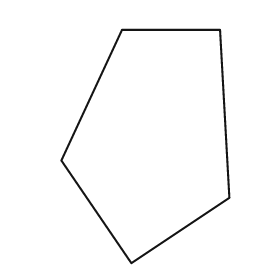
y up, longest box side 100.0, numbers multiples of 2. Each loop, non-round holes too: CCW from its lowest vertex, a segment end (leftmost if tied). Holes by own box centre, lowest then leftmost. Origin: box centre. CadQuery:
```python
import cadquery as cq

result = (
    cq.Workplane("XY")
    .moveTo(-6.0, -50.0)
    .lineTo(36.0, -22.0)
    .lineTo(32.0, 50.0)
    .lineTo(-10.0, 50.0)
    .lineTo(-36.0, -6.0)
    .close()
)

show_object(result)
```